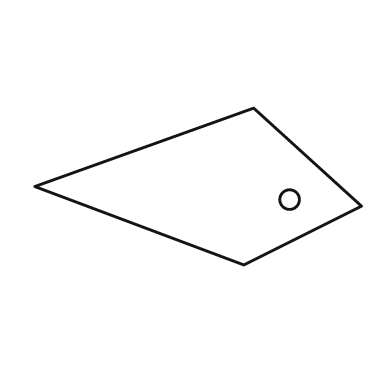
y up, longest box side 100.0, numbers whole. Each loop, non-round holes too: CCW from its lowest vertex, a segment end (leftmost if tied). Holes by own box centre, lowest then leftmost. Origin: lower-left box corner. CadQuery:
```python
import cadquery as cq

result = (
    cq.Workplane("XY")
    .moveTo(64.0, 0.0)
    .lineTo(100.0, 18.0)
    .lineTo(67.0, 48.0)
    .lineTo(0.0, 24.0)
    .close()
    .moveTo(78.0, 20.0)
    .circle(3.0)
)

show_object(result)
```